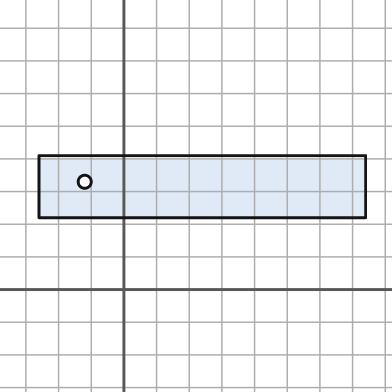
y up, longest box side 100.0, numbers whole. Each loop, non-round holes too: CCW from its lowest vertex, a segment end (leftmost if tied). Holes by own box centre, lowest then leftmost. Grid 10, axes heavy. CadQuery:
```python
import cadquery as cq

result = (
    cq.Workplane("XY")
    .moveTo(-26.0, 22.0)
    .lineTo(74.0, 22.0)
    .lineTo(74.0, 41.0)
    .lineTo(-26.0, 41.0)
    .close()
    .moveTo(-12.0, 33.0)
    .circle(2.0)
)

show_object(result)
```